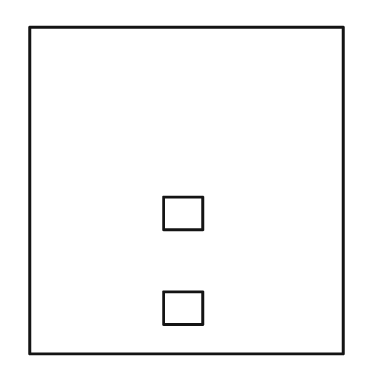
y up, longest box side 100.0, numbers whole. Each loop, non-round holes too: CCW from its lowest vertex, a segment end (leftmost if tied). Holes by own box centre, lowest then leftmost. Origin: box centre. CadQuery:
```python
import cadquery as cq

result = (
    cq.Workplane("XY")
    .moveTo(-48.0, -50.0)
    .lineTo(48.0, -50.0)
    .lineTo(48.0, 50.0)
    .lineTo(-48.0, 50.0)
    .close()
    .moveTo(-7.0, -41.0)
    .lineTo(5.0, -41.0)
    .lineTo(5.0, -31.0)
    .lineTo(-7.0, -31.0)
    .close()
    .moveTo(-7.0, -12.0)
    .lineTo(5.0, -12.0)
    .lineTo(5.0, -2.0)
    .lineTo(-7.0, -2.0)
    .close()
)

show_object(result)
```